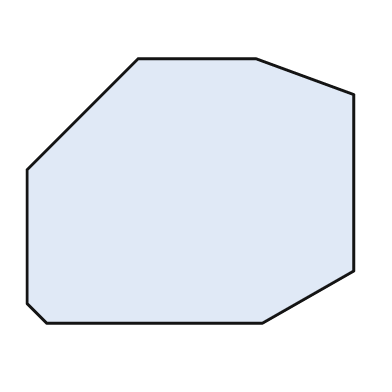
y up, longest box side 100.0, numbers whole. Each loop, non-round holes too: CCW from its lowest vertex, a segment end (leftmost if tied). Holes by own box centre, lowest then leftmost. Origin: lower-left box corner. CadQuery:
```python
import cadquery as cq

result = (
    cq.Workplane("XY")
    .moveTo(6.0, 0.0)
    .lineTo(72.0, 0.0)
    .lineTo(100.0, 16.0)
    .lineTo(100.0, 70.0)
    .lineTo(70.0, 81.0)
    .lineTo(34.0, 81.0)
    .lineTo(0.0, 47.0)
    .lineTo(0.0, 6.0)
    .close()
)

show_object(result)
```